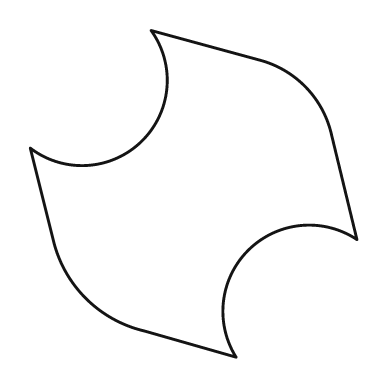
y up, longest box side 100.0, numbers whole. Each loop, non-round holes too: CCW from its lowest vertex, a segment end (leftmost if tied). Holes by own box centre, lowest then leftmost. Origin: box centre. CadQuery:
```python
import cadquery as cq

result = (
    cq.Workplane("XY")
    .moveTo(13.0, -50.0)
    .threePointArc((17.0, -17.0), (50.0, -14.0))
    .lineTo(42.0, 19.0)
    .threePointArc((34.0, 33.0), (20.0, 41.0))
    .lineTo(-13.0, 50.0)
    .threePointArc((-16.0, 16.0), (-50.0, 14.0))
    .lineTo(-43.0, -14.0)
    .threePointArc((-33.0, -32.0), (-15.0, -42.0))
    .close()
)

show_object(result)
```